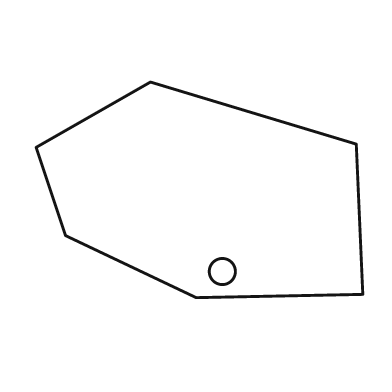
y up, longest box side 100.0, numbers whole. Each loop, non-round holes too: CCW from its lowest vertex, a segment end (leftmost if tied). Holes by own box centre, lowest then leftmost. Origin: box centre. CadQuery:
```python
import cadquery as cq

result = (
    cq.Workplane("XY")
    .moveTo(-1.0, -33.0)
    .lineTo(50.0, -32.0)
    .lineTo(48.0, 14.0)
    .lineTo(-15.0, 33.0)
    .lineTo(-50.0, 13.0)
    .lineTo(-41.0, -14.0)
    .close()
    .moveTo(7.0, -25.0)
    .circle(4.0)
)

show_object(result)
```